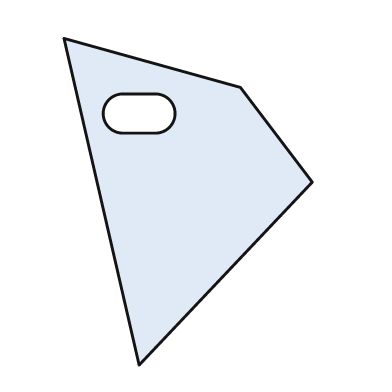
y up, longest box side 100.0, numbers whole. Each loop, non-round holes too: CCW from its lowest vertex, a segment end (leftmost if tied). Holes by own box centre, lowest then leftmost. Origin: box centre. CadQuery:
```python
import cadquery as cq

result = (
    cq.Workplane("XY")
    .moveTo(-15.0, -50.0)
    .lineTo(38.0, 6.0)
    .lineTo(16.0, 35.0)
    .lineTo(-38.0, 50.0)
    .close()
    .moveTo(-20.0, 21.0)
    .lineTo(-10.0, 21.0)
    .threePointArc((-4.0, 27.0), (-10.0, 33.0))
    .lineTo(-20.0, 33.0)
    .threePointArc((-26.0, 27.0), (-20.0, 21.0))
    .close()
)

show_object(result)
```